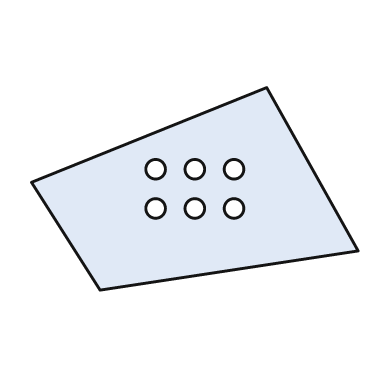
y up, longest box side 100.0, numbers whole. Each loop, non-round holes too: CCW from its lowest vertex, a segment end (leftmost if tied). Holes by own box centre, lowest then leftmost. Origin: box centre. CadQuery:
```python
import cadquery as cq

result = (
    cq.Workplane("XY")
    .moveTo(-29.0, -31.0)
    .lineTo(50.0, -19.0)
    .lineTo(22.0, 31.0)
    .lineTo(-50.0, 2.0)
    .close()
    .moveTo(-12.0, -6.0)
    .circle(3.0)
    .moveTo(0.0, -6.0)
    .circle(3.0)
    .moveTo(12.0, -6.0)
    .circle(3.0)
    .moveTo(-12.0, 6.0)
    .circle(3.0)
    .moveTo(0.0, 6.0)
    .circle(3.0)
    .moveTo(12.0, 6.0)
    .circle(3.0)
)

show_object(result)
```